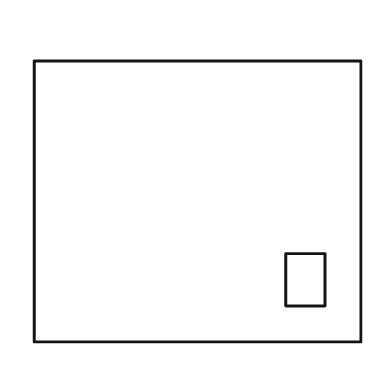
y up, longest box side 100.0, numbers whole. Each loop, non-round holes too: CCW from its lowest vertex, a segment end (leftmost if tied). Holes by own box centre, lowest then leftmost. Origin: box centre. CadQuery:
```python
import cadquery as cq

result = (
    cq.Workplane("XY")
    .moveTo(-50.0, -43.0)
    .lineTo(50.0, -43.0)
    .lineTo(50.0, 43.0)
    .lineTo(-50.0, 43.0)
    .close()
    .moveTo(27.0, -32.0)
    .lineTo(39.0, -32.0)
    .lineTo(39.0, -16.0)
    .lineTo(27.0, -16.0)
    .close()
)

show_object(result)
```